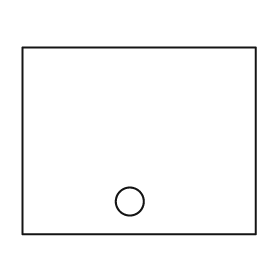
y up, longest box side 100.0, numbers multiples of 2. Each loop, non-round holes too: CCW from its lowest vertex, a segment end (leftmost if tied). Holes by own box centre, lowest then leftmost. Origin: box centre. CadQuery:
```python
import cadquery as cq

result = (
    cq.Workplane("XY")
    .moveTo(-50.0, -40.0)
    .lineTo(50.0, -40.0)
    .lineTo(50.0, 40.0)
    .lineTo(-50.0, 40.0)
    .close()
    .moveTo(-4.0, -26.0)
    .circle(6.0)
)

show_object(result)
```